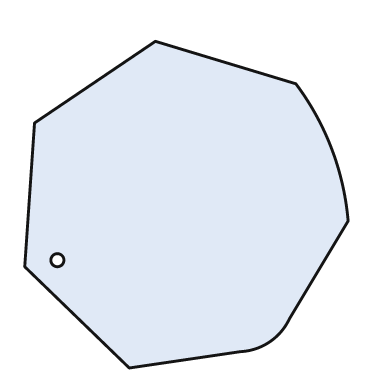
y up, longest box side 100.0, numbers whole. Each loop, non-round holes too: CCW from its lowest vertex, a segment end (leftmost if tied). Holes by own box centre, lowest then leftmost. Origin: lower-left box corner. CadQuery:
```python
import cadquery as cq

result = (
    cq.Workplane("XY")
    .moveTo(32.0, 0.0)
    .lineTo(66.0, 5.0)
    .threePointArc((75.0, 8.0), (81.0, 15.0))
    .lineTo(99.0, 45.0)
    .threePointArc((94.0, 67.0), (83.0, 87.0))
    .lineTo(40.0, 100.0)
    .lineTo(3.0, 75.0)
    .lineTo(0.0, 31.0)
    .close()
    .moveTo(10.0, 33.0)
    .circle(2.0)
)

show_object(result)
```